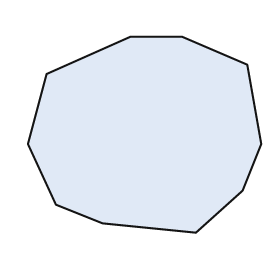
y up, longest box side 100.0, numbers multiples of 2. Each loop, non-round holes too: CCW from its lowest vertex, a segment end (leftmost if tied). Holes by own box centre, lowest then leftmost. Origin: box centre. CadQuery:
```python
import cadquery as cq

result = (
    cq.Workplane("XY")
    .moveTo(22.0, -42.0)
    .lineTo(42.0, -24.0)
    .lineTo(50.0, -4.0)
    .lineTo(44.0, 30.0)
    .lineTo(16.0, 42.0)
    .lineTo(-6.0, 42.0)
    .lineTo(-42.0, 26.0)
    .lineTo(-50.0, -4.0)
    .lineTo(-38.0, -30.0)
    .lineTo(-18.0, -38.0)
    .close()
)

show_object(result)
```